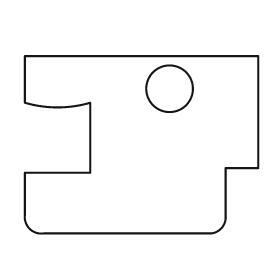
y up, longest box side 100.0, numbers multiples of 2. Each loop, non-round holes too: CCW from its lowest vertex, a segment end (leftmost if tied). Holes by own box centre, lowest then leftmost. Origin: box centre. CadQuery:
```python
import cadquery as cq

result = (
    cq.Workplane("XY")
    .moveTo(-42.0, -38.0)
    .lineTo(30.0, -38.0)
    .threePointArc((34.0, -36.0), (36.0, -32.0))
    .lineTo(36.0, -10.0)
    .lineTo(50.0, -10.0)
    .lineTo(50.0, 38.0)
    .lineTo(-50.0, 38.0)
    .lineTo(-50.0, 18.0)
    .threePointArc((-36.0, 16.0), (-22.0, 18.0))
    .lineTo(-22.0, -12.0)
    .lineTo(-50.0, -12.0)
    .lineTo(-50.0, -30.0)
    .threePointArc((-48.0, -36.0), (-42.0, -38.0))
    .close()
    .moveTo(12.0, 24.0)
    .circle(10.0)
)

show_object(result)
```